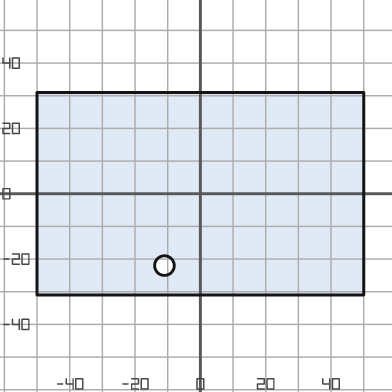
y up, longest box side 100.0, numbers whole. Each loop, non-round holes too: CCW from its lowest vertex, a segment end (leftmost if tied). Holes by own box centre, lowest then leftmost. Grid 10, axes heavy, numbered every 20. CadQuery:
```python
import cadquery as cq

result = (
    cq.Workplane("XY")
    .moveTo(-50.0, -31.0)
    .lineTo(50.0, -31.0)
    .lineTo(50.0, 31.0)
    .lineTo(-50.0, 31.0)
    .close()
    .moveTo(-11.0, -22.0)
    .circle(3.0)
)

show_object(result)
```